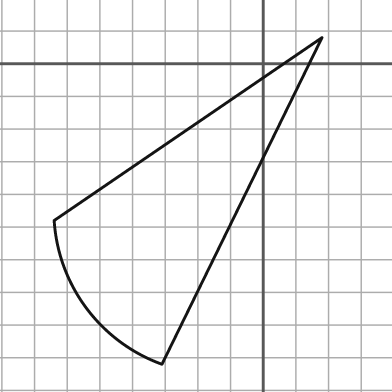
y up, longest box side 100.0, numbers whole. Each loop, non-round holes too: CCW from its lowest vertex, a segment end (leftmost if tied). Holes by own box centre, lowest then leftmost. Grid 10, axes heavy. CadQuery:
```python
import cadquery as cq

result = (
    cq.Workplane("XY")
    .moveTo(-31.0, -92.0)
    .lineTo(18.0, 8.0)
    .lineTo(-64.0, -48.0)
    .threePointArc((-54.0, -75.0), (-31.0, -92.0))
    .close()
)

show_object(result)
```